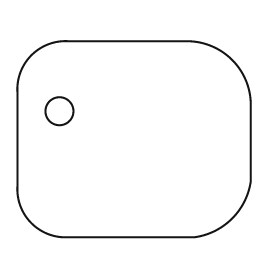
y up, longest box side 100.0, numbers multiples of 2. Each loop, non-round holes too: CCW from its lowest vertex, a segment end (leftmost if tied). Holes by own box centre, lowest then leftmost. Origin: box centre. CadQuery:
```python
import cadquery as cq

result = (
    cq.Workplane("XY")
    .moveTo(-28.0, -42.0)
    .lineTo(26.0, -42.0)
    .threePointArc((42.0, -34.0), (50.0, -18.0))
    .lineTo(50.0, 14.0)
    .threePointArc((42.0, 34.0), (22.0, 42.0))
    .lineTo(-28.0, 42.0)
    .threePointArc((-44.0, 36.0), (-50.0, 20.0))
    .lineTo(-50.0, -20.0)
    .threePointArc((-44.0, -36.0), (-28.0, -42.0))
    .close()
    .moveTo(-32.0, 12.0)
    .circle(6.0)
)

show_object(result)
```